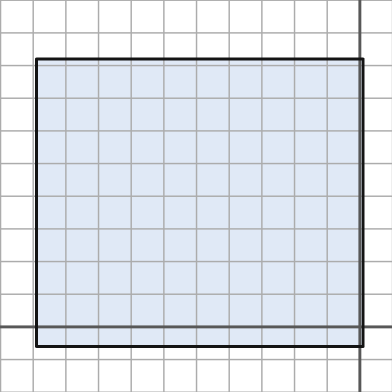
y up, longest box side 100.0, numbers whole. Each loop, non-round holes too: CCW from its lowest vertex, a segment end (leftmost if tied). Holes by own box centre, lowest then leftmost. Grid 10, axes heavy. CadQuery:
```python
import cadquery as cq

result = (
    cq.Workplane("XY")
    .moveTo(-99.0, -6.0)
    .lineTo(1.0, -6.0)
    .lineTo(1.0, 82.0)
    .lineTo(-99.0, 82.0)
    .close()
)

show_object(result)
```